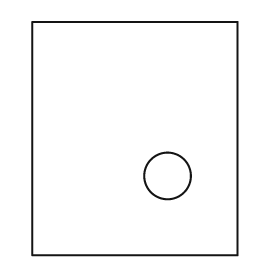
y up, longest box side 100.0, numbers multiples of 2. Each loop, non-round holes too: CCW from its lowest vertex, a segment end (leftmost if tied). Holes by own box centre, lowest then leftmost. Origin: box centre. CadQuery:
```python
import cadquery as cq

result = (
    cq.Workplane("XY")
    .moveTo(-44.0, -50.0)
    .lineTo(44.0, -50.0)
    .lineTo(44.0, 50.0)
    .lineTo(-44.0, 50.0)
    .close()
    .moveTo(14.0, -16.0)
    .circle(10.0)
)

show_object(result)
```